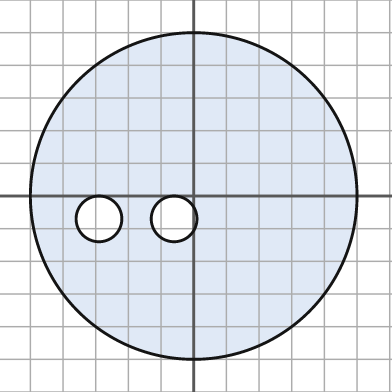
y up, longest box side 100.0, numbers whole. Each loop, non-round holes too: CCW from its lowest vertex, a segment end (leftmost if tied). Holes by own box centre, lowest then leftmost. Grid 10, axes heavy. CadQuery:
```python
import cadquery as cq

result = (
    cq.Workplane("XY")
    .moveTo(0.0, 0.0)
    .circle(50.0)
    .moveTo(-29.0, -7.0)
    .circle(7.0)
    .moveTo(-6.0, -7.0)
    .circle(7.0)
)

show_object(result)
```